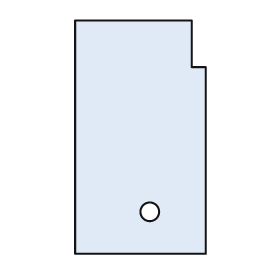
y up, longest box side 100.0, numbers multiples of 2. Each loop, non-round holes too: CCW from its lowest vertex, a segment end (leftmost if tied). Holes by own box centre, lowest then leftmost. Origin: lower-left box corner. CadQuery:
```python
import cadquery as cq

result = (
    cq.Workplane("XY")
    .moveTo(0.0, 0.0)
    .lineTo(56.0, 0.0)
    .lineTo(56.0, 80.0)
    .lineTo(50.0, 80.0)
    .lineTo(50.0, 100.0)
    .lineTo(0.0, 100.0)
    .close()
    .moveTo(32.0, 18.0)
    .circle(4.0)
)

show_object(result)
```